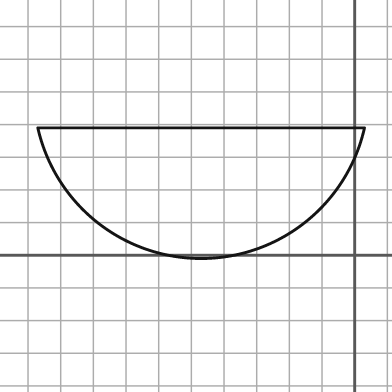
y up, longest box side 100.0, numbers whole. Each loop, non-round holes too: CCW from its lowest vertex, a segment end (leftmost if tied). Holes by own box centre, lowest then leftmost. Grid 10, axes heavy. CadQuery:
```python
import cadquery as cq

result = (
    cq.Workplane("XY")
    .moveTo(-97.0, 39.0)
    .threePointArc((-47.0, -1.0), (3.0, 39.0))
    .close()
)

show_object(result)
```